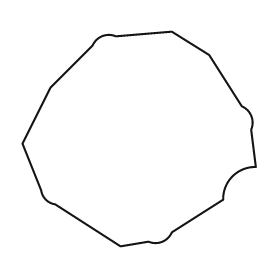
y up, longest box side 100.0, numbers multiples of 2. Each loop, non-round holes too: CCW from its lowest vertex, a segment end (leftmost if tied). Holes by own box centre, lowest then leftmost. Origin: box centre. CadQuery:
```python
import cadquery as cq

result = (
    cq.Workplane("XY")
    .moveTo(-8.0, -46.0)
    .lineTo(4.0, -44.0)
    .threePointArc((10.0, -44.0), (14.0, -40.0))
    .lineTo(36.0, -26.0)
    .threePointArc((40.0, -16.0), (50.0, -12.0))
    .lineTo(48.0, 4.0)
    .threePointArc((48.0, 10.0), (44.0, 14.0))
    .lineTo(30.0, 36.0)
    .lineTo(14.0, 46.0)
    .lineTo(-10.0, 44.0)
    .threePointArc((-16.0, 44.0), (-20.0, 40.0))
    .lineTo(-38.0, 22.0)
    .lineTo(-50.0, -2.0)
    .lineTo(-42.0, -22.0)
    .threePointArc((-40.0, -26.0), (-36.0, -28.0))
    .close()
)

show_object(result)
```